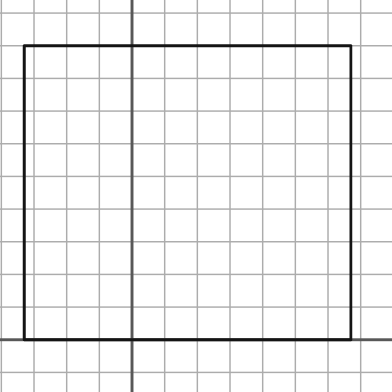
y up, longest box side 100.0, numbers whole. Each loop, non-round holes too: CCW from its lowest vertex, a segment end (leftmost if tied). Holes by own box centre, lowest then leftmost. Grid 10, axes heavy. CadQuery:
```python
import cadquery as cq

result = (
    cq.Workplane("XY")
    .moveTo(-33.0, 0.0)
    .lineTo(67.0, 0.0)
    .lineTo(67.0, 90.0)
    .lineTo(-33.0, 90.0)
    .close()
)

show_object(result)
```